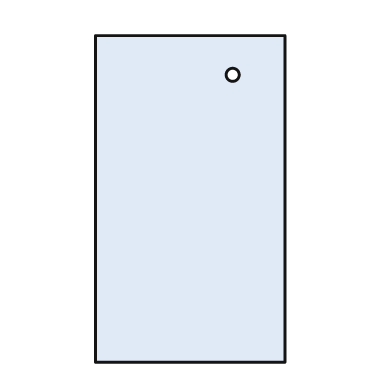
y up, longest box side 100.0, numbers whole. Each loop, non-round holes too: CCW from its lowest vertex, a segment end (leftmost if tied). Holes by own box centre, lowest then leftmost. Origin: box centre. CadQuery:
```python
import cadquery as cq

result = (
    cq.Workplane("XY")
    .moveTo(-29.0, -50.0)
    .lineTo(29.0, -50.0)
    .lineTo(29.0, 50.0)
    .lineTo(-29.0, 50.0)
    .close()
    .moveTo(13.0, 38.0)
    .circle(2.0)
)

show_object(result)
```